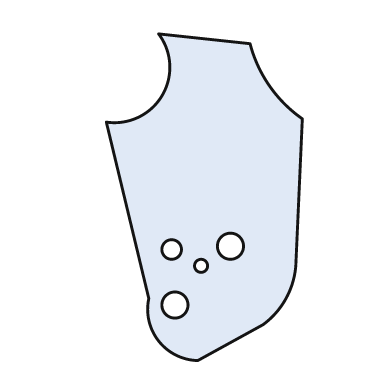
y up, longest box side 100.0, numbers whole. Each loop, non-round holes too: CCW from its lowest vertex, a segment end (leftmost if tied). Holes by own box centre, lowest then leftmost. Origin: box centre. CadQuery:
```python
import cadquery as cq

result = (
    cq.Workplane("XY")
    .moveTo(-2.0, -50.0)
    .lineTo(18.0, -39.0)
    .threePointArc((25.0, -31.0), (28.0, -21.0))
    .lineTo(30.0, 24.0)
    .threePointArc((20.0, 34.0), (14.0, 47.0))
    .lineTo(-14.0, 50.0)
    .threePointArc((-13.0, 31.0), (-30.0, 23.0))
    .lineTo(-17.0, -31.0)
    .threePointArc((-14.0, -44.0), (-2.0, -50.0))
    .close()
    .moveTo(-9.0, -33.0)
    .circle(4.0)
    .moveTo(-1.0, -21.0)
    .circle(2.0)
    .moveTo(-10.0, -16.0)
    .circle(3.0)
    .moveTo(8.0, -15.0)
    .circle(4.0)
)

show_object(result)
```